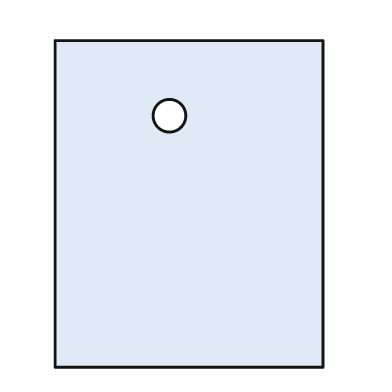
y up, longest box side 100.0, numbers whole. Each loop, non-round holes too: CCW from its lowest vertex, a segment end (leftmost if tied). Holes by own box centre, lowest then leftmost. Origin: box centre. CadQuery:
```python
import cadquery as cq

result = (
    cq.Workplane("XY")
    .moveTo(-41.0, -50.0)
    .lineTo(41.0, -50.0)
    .lineTo(41.0, 50.0)
    .lineTo(-41.0, 50.0)
    .close()
    .moveTo(-6.0, 27.0)
    .circle(5.0)
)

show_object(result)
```